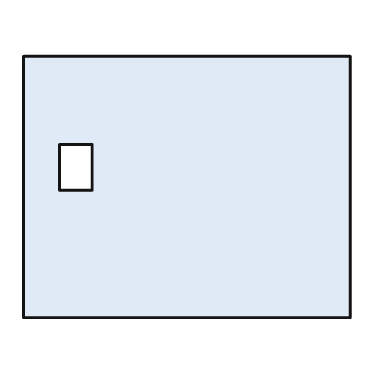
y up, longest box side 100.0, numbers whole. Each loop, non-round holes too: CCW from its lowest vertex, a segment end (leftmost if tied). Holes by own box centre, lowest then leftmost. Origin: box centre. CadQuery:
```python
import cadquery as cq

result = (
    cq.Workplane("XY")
    .moveTo(-50.0, -40.0)
    .lineTo(50.0, -40.0)
    .lineTo(50.0, 40.0)
    .lineTo(-50.0, 40.0)
    .close()
    .moveTo(-39.0, -1.0)
    .lineTo(-29.0, -1.0)
    .lineTo(-29.0, 13.0)
    .lineTo(-39.0, 13.0)
    .close()
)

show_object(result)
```